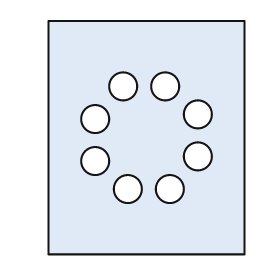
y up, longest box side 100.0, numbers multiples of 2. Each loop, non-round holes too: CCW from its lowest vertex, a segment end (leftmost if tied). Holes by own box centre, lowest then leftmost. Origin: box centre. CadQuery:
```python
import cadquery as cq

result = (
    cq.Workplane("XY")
    .moveTo(-42.0, -50.0)
    .lineTo(42.0, -50.0)
    .lineTo(42.0, 50.0)
    .lineTo(-42.0, 50.0)
    .close()
    .moveTo(-8.0, -22.0)
    .circle(6.0)
    .moveTo(10.0, -22.0)
    .circle(6.0)
    .moveTo(-22.0, -10.0)
    .circle(6.0)
    .moveTo(22.0, -8.0)
    .circle(6.0)
    .moveTo(-22.0, 8.0)
    .circle(6.0)
    .moveTo(22.0, 10.0)
    .circle(6.0)
    .moveTo(-10.0, 22.0)
    .circle(6.0)
    .moveTo(8.0, 22.0)
    .circle(6.0)
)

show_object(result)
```